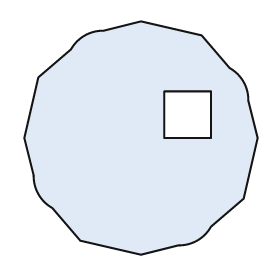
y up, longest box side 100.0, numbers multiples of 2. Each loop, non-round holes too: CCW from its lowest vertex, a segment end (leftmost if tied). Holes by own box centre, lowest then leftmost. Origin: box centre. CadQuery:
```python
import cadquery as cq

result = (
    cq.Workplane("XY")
    .moveTo(0.0, -50.0)
    .lineTo(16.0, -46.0)
    .threePointArc((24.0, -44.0), (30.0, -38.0))
    .lineTo(44.0, -26.0)
    .lineTo(50.0, 0.0)
    .lineTo(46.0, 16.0)
    .threePointArc((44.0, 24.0), (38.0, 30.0))
    .lineTo(26.0, 44.0)
    .lineTo(0.0, 50.0)
    .lineTo(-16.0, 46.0)
    .threePointArc((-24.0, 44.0), (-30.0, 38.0))
    .lineTo(-44.0, 26.0)
    .lineTo(-50.0, 0.0)
    .lineTo(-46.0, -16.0)
    .threePointArc((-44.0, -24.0), (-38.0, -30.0))
    .lineTo(-26.0, -44.0)
    .close()
    .moveTo(10.0, 0.0)
    .lineTo(30.0, 0.0)
    .lineTo(30.0, 20.0)
    .lineTo(10.0, 20.0)
    .close()
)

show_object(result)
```